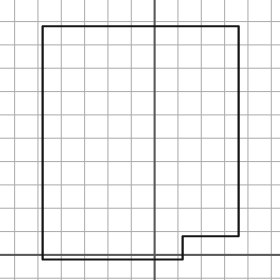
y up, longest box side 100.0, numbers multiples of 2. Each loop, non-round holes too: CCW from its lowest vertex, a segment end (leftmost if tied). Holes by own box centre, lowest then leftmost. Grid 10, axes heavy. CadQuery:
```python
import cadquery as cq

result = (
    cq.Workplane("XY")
    .moveTo(-48.0, -2.0)
    .lineTo(12.0, -2.0)
    .lineTo(12.0, 8.0)
    .lineTo(36.0, 8.0)
    .lineTo(36.0, 98.0)
    .lineTo(-48.0, 98.0)
    .close()
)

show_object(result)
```